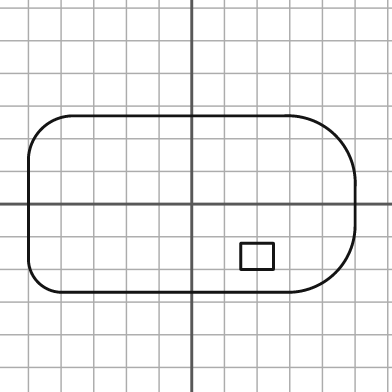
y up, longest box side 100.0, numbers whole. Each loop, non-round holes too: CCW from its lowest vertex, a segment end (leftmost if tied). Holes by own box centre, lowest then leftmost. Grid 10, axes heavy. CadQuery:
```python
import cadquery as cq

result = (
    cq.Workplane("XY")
    .moveTo(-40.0, -27.0)
    .lineTo(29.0, -27.0)
    .threePointArc((44.0, -21.0), (50.0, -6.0))
    .lineTo(50.0, 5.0)
    .threePointArc((44.0, 21.0), (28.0, 27.0))
    .lineTo(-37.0, 27.0)
    .threePointArc((-46.0, 23.0), (-50.0, 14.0))
    .lineTo(-50.0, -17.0)
    .threePointArc((-47.0, -24.0), (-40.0, -27.0))
    .close()
    .moveTo(15.0, -20.0)
    .lineTo(25.0, -20.0)
    .lineTo(25.0, -12.0)
    .lineTo(15.0, -12.0)
    .close()
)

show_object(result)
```